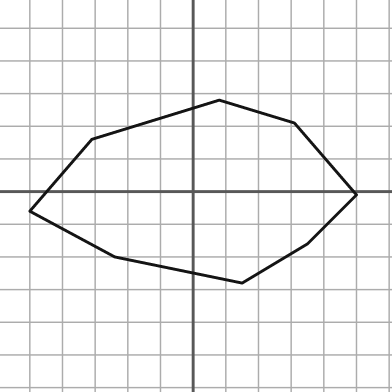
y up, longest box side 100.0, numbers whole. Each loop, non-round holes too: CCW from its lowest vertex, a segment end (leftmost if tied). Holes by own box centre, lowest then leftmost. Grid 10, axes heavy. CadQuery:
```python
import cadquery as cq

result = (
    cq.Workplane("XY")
    .moveTo(15.0, -28.0)
    .lineTo(35.0, -16.0)
    .lineTo(50.0, -1.0)
    .lineTo(31.0, 21.0)
    .lineTo(8.0, 28.0)
    .lineTo(-31.0, 16.0)
    .lineTo(-50.0, -6.0)
    .lineTo(-24.0, -20.0)
    .close()
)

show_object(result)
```